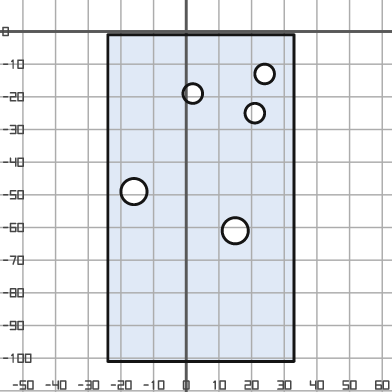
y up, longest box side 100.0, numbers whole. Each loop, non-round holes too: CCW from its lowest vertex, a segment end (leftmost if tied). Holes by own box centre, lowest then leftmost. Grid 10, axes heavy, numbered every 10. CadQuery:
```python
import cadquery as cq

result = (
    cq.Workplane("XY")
    .moveTo(-24.0, -101.0)
    .lineTo(33.0, -101.0)
    .lineTo(33.0, -1.0)
    .lineTo(-24.0, -1.0)
    .close()
    .moveTo(15.0, -61.0)
    .circle(4.0)
    .moveTo(-16.0, -49.0)
    .circle(4.0)
    .moveTo(21.0, -25.0)
    .circle(3.0)
    .moveTo(2.0, -19.0)
    .circle(3.0)
    .moveTo(24.0, -13.0)
    .circle(3.0)
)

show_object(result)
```